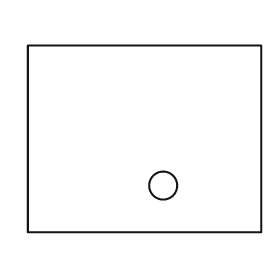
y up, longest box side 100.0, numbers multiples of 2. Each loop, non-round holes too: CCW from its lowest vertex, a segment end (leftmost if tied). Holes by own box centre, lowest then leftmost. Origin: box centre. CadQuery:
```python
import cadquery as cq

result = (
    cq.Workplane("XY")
    .moveTo(-50.0, -40.0)
    .lineTo(50.0, -40.0)
    .lineTo(50.0, 40.0)
    .lineTo(-50.0, 40.0)
    .close()
    .moveTo(8.0, -20.0)
    .circle(6.0)
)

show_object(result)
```